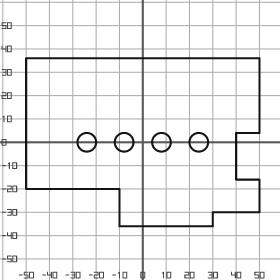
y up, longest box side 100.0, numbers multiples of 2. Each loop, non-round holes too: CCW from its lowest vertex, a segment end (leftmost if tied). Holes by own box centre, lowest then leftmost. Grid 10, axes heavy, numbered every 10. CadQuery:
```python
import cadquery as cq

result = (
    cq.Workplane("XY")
    .moveTo(-10.0, -36.0)
    .lineTo(30.0, -36.0)
    .lineTo(30.0, -30.0)
    .lineTo(50.0, -30.0)
    .lineTo(50.0, -16.0)
    .lineTo(40.0, -16.0)
    .lineTo(40.0, 4.0)
    .lineTo(50.0, 4.0)
    .lineTo(50.0, 36.0)
    .lineTo(-50.0, 36.0)
    .lineTo(-50.0, -20.0)
    .lineTo(-10.0, -20.0)
    .close()
    .moveTo(-24.0, 0.0)
    .circle(4.0)
    .moveTo(-8.0, 0.0)
    .circle(4.0)
    .moveTo(8.0, 0.0)
    .circle(4.0)
    .moveTo(24.0, 0.0)
    .circle(4.0)
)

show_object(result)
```